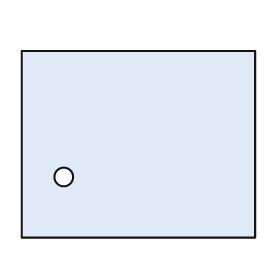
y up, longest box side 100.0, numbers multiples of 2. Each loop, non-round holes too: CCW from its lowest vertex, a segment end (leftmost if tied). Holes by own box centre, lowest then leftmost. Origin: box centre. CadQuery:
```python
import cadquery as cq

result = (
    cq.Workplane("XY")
    .moveTo(-50.0, -40.0)
    .lineTo(50.0, -40.0)
    .lineTo(50.0, 40.0)
    .lineTo(-50.0, 40.0)
    .close()
    .moveTo(-32.0, -14.0)
    .circle(4.0)
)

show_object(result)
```